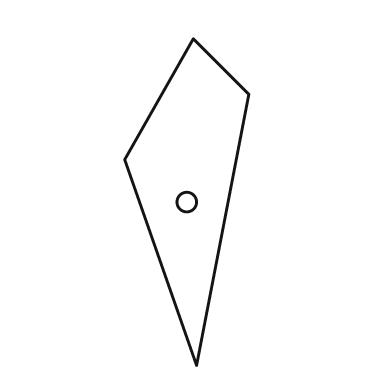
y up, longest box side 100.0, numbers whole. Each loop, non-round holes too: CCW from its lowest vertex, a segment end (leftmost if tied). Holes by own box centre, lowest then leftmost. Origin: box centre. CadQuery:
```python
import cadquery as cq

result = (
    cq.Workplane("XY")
    .moveTo(3.0, -50.0)
    .lineTo(19.0, 33.0)
    .lineTo(2.0, 50.0)
    .lineTo(-19.0, 13.0)
    .close()
    .moveTo(0.0, 0.0)
    .circle(3.0)
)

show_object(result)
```